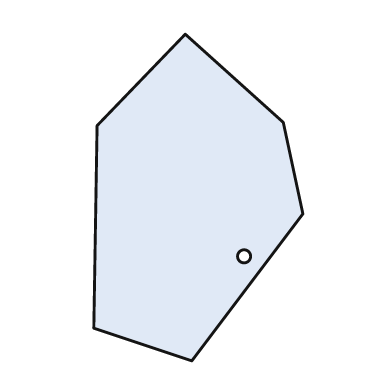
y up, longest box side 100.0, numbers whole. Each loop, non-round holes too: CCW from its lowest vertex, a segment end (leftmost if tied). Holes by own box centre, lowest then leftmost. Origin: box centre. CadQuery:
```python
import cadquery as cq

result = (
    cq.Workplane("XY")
    .moveTo(-2.0, -50.0)
    .lineTo(32.0, -5.0)
    .lineTo(26.0, 23.0)
    .lineTo(-4.0, 50.0)
    .lineTo(-31.0, 22.0)
    .lineTo(-32.0, -40.0)
    .close()
    .moveTo(14.0, -18.0)
    .circle(2.0)
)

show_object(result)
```